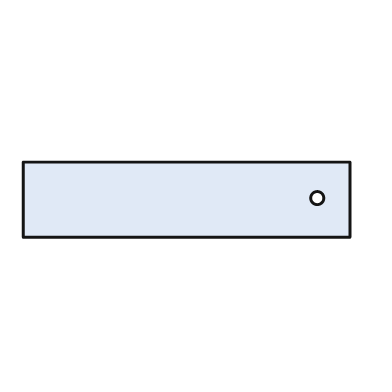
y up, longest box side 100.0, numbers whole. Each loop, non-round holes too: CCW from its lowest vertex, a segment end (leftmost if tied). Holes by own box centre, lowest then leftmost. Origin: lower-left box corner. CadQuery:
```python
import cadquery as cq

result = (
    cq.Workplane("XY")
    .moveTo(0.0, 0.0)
    .lineTo(100.0, 0.0)
    .lineTo(100.0, 23.0)
    .lineTo(0.0, 23.0)
    .close()
    .moveTo(90.0, 12.0)
    .circle(2.0)
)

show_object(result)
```